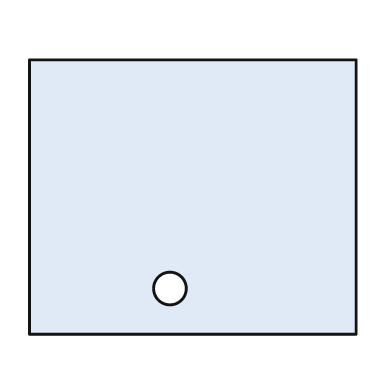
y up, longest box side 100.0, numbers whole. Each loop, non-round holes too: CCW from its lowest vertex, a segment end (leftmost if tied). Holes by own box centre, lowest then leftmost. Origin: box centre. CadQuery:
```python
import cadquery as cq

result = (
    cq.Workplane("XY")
    .moveTo(-50.0, -42.0)
    .lineTo(50.0, -42.0)
    .lineTo(50.0, 42.0)
    .lineTo(-50.0, 42.0)
    .close()
    .moveTo(-7.0, -28.0)
    .circle(5.0)
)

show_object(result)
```